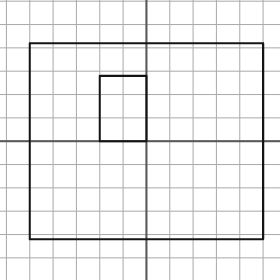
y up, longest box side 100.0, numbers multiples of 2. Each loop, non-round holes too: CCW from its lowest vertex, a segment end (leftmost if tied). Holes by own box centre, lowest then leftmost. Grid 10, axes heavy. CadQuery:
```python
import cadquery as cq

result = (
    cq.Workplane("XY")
    .moveTo(-50.0, -42.0)
    .lineTo(50.0, -42.0)
    .lineTo(50.0, 42.0)
    .lineTo(-50.0, 42.0)
    .close()
    .moveTo(-20.0, 0.0)
    .lineTo(0.0, 0.0)
    .lineTo(0.0, 28.0)
    .lineTo(-20.0, 28.0)
    .close()
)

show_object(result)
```